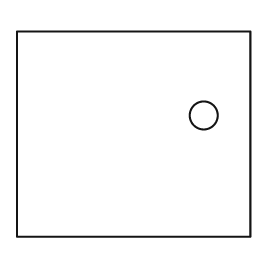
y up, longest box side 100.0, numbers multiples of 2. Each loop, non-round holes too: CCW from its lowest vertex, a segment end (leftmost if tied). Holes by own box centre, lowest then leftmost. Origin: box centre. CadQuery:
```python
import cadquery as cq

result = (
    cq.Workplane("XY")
    .moveTo(-50.0, -44.0)
    .lineTo(50.0, -44.0)
    .lineTo(50.0, 44.0)
    .lineTo(-50.0, 44.0)
    .close()
    .moveTo(30.0, 8.0)
    .circle(6.0)
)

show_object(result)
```